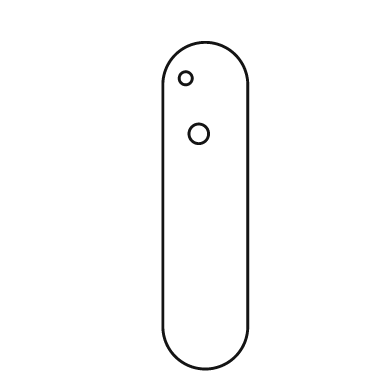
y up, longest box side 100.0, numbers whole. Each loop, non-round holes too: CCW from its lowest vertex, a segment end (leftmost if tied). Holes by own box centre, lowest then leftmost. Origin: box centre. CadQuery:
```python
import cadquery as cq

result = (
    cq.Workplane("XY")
    .moveTo(-13.0, -37.0)
    .threePointArc((0.0, -50.0), (13.0, -37.0))
    .lineTo(13.0, 37.0)
    .threePointArc((0.0, 50.0), (-13.0, 37.0))
    .close()
    .moveTo(-2.0, 22.0)
    .circle(3.0)
    .moveTo(-6.0, 39.0)
    .circle(2.0)
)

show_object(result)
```